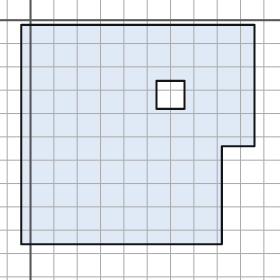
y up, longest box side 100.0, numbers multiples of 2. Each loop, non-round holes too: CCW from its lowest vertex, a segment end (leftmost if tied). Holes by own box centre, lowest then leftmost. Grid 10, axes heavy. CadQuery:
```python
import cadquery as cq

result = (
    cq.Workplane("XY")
    .moveTo(-4.0, -96.0)
    .lineTo(82.0, -96.0)
    .lineTo(82.0, -54.0)
    .lineTo(96.0, -54.0)
    .lineTo(96.0, -2.0)
    .lineTo(-4.0, -2.0)
    .close()
    .moveTo(54.0, -38.0)
    .lineTo(66.0, -38.0)
    .lineTo(66.0, -26.0)
    .lineTo(54.0, -26.0)
    .close()
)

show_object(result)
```